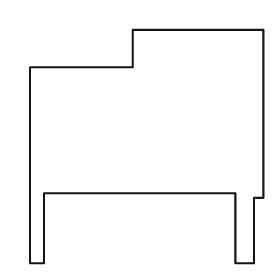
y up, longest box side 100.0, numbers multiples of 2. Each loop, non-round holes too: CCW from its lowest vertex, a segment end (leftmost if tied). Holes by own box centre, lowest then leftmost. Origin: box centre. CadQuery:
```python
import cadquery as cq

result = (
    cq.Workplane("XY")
    .moveTo(-50.0, -50.0)
    .lineTo(-44.0, -50.0)
    .lineTo(-44.0, -20.0)
    .lineTo(38.0, -20.0)
    .lineTo(38.0, -50.0)
    .lineTo(46.0, -50.0)
    .lineTo(46.0, -22.0)
    .lineTo(50.0, -22.0)
    .lineTo(50.0, 50.0)
    .lineTo(-6.0, 50.0)
    .lineTo(-6.0, 34.0)
    .lineTo(-50.0, 34.0)
    .close()
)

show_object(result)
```